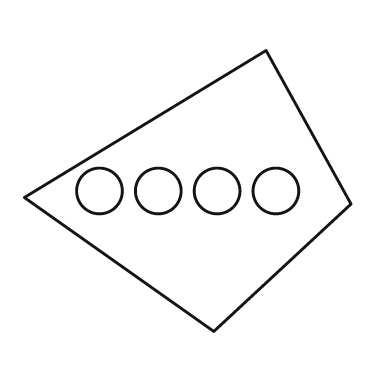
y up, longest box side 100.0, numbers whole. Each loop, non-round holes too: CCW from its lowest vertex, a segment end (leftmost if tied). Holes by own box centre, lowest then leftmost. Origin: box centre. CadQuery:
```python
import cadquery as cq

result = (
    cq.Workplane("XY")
    .moveTo(8.0, -43.0)
    .lineTo(50.0, -4.0)
    .lineTo(24.0, 43.0)
    .lineTo(-50.0, -2.0)
    .close()
    .moveTo(-27.0, 0.0)
    .circle(7.0)
    .moveTo(-9.0, 0.0)
    .circle(7.0)
    .moveTo(9.0, 0.0)
    .circle(7.0)
    .moveTo(27.0, 0.0)
    .circle(7.0)
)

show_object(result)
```